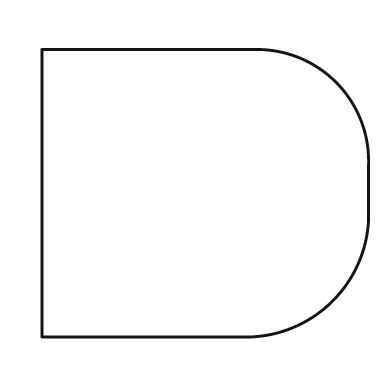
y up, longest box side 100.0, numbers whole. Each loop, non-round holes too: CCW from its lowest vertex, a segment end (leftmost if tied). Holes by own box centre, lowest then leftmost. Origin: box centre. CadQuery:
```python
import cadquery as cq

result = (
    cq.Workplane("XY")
    .moveTo(-50.0, -44.0)
    .lineTo(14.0, -44.0)
    .threePointArc((39.0, -33.0), (50.0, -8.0))
    .lineTo(50.0, 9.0)
    .threePointArc((40.0, 34.0), (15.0, 44.0))
    .lineTo(-50.0, 44.0)
    .close()
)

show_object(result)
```